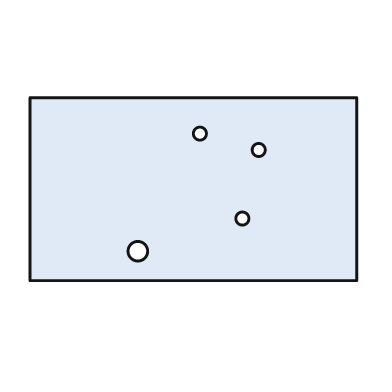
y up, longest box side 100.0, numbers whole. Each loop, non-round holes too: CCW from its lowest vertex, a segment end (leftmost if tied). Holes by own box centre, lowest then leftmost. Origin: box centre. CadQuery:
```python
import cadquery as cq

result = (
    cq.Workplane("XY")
    .moveTo(-50.0, -28.0)
    .lineTo(50.0, -28.0)
    .lineTo(50.0, 28.0)
    .lineTo(-50.0, 28.0)
    .close()
    .moveTo(-17.0, -19.0)
    .circle(3.0)
    .moveTo(15.0, -9.0)
    .circle(2.0)
    .moveTo(20.0, 12.0)
    .circle(2.0)
    .moveTo(2.0, 17.0)
    .circle(2.0)
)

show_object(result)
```